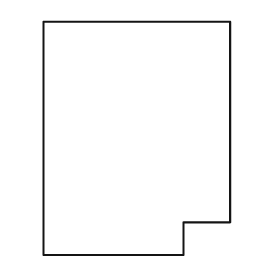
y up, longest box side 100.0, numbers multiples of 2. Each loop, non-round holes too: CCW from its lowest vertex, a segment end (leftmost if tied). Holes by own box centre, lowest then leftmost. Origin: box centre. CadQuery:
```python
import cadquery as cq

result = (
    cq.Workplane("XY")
    .moveTo(-40.0, -50.0)
    .lineTo(20.0, -50.0)
    .lineTo(20.0, -36.0)
    .lineTo(40.0, -36.0)
    .lineTo(40.0, 50.0)
    .lineTo(-40.0, 50.0)
    .close()
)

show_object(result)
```